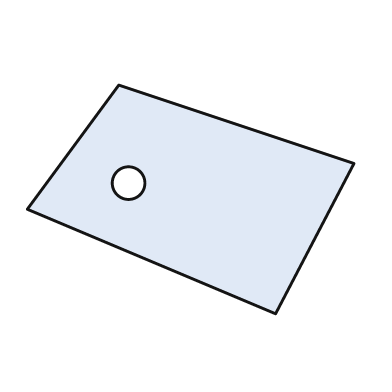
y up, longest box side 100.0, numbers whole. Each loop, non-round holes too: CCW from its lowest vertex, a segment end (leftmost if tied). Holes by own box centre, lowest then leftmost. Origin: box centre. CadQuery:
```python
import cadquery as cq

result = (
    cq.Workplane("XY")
    .moveTo(26.0, -35.0)
    .lineTo(50.0, 11.0)
    .lineTo(-22.0, 35.0)
    .lineTo(-50.0, -3.0)
    .close()
    .moveTo(-19.0, 5.0)
    .circle(5.0)
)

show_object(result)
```